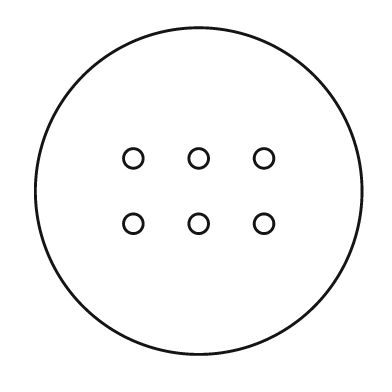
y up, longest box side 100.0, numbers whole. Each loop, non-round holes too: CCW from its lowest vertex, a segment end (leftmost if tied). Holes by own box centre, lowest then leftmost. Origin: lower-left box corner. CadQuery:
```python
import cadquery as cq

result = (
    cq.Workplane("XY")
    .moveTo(50.0, 50.0)
    .circle(50.0)
    .moveTo(30.0, 40.0)
    .circle(3.0)
    .moveTo(50.0, 40.0)
    .circle(3.0)
    .moveTo(70.0, 40.0)
    .circle(3.0)
    .moveTo(30.0, 60.0)
    .circle(3.0)
    .moveTo(50.0, 60.0)
    .circle(3.0)
    .moveTo(70.0, 60.0)
    .circle(3.0)
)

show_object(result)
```